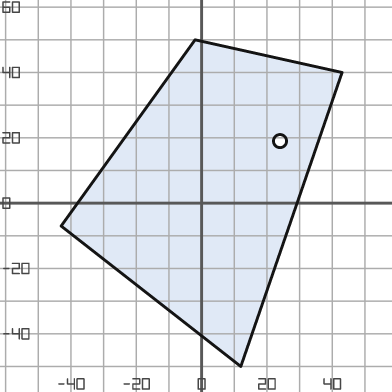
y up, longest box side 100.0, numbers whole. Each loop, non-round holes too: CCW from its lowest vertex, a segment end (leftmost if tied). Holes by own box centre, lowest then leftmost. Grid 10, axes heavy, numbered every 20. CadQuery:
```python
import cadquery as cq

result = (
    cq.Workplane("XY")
    .moveTo(12.0, -50.0)
    .lineTo(43.0, 40.0)
    .lineTo(-2.0, 50.0)
    .lineTo(-43.0, -7.0)
    .close()
    .moveTo(24.0, 19.0)
    .circle(2.0)
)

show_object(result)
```